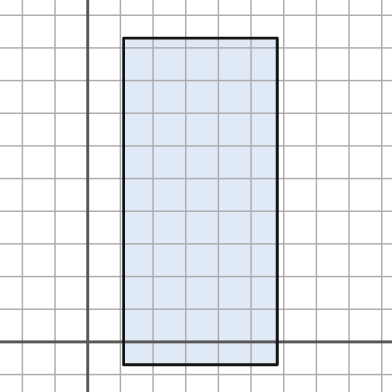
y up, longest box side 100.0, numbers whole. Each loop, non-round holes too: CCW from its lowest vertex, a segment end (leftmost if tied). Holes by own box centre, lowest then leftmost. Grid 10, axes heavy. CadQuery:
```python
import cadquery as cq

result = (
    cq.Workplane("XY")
    .moveTo(11.0, -7.0)
    .lineTo(58.0, -7.0)
    .lineTo(58.0, 93.0)
    .lineTo(11.0, 93.0)
    .close()
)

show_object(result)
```